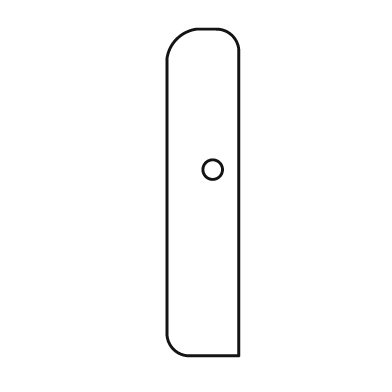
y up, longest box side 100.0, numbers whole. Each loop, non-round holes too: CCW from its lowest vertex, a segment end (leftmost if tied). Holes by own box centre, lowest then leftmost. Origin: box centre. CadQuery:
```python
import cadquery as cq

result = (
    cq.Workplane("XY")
    .moveTo(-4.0, -50.0)
    .lineTo(11.0, -50.0)
    .lineTo(11.0, 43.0)
    .threePointArc((9.0, 48.0), (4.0, 50.0))
    .lineTo(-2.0, 50.0)
    .threePointArc((-8.0, 47.0), (-11.0, 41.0))
    .lineTo(-11.0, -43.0)
    .threePointArc((-9.0, -48.0), (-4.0, -50.0))
    .close()
    .moveTo(3.0, 7.0)
    .circle(3.0)
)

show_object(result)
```